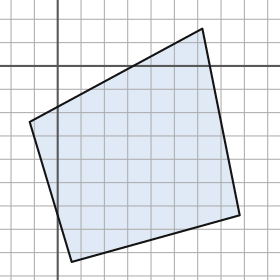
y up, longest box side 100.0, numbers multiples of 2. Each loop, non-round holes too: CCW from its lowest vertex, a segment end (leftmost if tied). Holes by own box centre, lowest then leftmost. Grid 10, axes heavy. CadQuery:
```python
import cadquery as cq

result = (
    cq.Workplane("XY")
    .moveTo(6.0, -84.0)
    .lineTo(78.0, -64.0)
    .lineTo(62.0, 16.0)
    .lineTo(-12.0, -24.0)
    .close()
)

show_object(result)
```